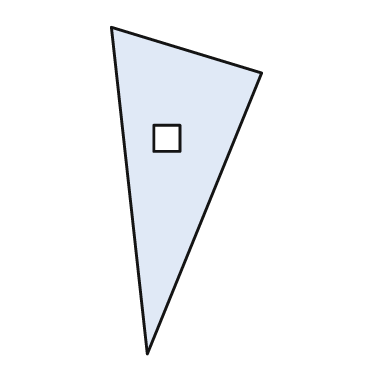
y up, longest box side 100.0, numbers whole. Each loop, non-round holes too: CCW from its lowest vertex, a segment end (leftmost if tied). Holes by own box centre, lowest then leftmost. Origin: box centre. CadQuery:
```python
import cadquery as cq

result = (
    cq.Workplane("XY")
    .moveTo(-12.0, -50.0)
    .lineTo(23.0, 36.0)
    .lineTo(-23.0, 50.0)
    .close()
    .moveTo(-10.0, 12.0)
    .lineTo(-2.0, 12.0)
    .lineTo(-2.0, 20.0)
    .lineTo(-10.0, 20.0)
    .close()
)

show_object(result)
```